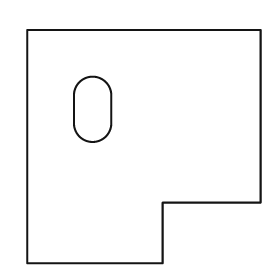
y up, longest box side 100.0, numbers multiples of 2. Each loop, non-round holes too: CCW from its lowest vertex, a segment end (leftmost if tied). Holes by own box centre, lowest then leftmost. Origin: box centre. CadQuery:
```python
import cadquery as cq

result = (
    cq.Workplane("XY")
    .moveTo(-50.0, -50.0)
    .lineTo(8.0, -50.0)
    .lineTo(8.0, -24.0)
    .lineTo(50.0, -24.0)
    .lineTo(50.0, 50.0)
    .lineTo(-50.0, 50.0)
    .close()
    .moveTo(-30.0, 10.0)
    .threePointArc((-22.0, 2.0), (-14.0, 10.0))
    .lineTo(-14.0, 22.0)
    .threePointArc((-22.0, 30.0), (-30.0, 22.0))
    .close()
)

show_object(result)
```